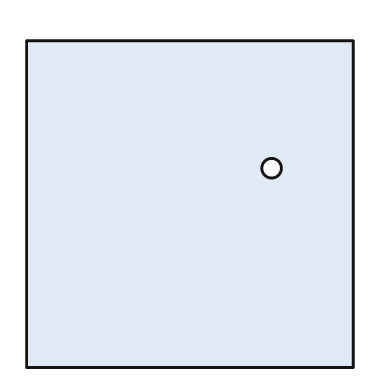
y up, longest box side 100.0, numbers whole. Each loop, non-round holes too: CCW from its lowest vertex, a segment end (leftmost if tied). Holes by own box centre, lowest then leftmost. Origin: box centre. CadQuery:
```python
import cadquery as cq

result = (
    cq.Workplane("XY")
    .moveTo(-50.0, -50.0)
    .lineTo(50.0, -50.0)
    .lineTo(50.0, 50.0)
    .lineTo(-50.0, 50.0)
    .close()
    .moveTo(25.0, 11.0)
    .circle(3.0)
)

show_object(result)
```